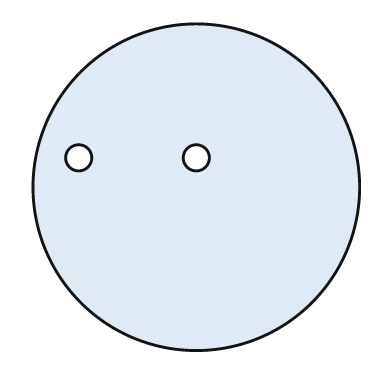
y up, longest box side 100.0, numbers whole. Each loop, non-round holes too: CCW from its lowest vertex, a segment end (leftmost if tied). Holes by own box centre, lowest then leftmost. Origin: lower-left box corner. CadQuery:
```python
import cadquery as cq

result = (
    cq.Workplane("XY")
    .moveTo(50.0, 50.0)
    .circle(50.0)
    .moveTo(14.0, 59.0)
    .circle(4.0)
    .moveTo(50.0, 59.0)
    .circle(4.0)
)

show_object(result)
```